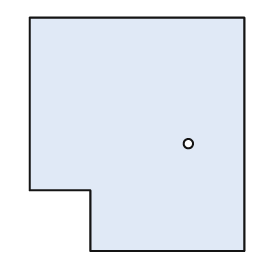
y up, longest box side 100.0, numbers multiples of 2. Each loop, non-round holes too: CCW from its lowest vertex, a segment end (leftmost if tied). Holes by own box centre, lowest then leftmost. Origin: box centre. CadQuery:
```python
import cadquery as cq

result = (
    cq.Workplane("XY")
    .moveTo(-20.0, -50.0)
    .lineTo(46.0, -50.0)
    .lineTo(46.0, 50.0)
    .lineTo(-46.0, 50.0)
    .lineTo(-46.0, -24.0)
    .lineTo(-20.0, -24.0)
    .close()
    .moveTo(22.0, -4.0)
    .circle(2.0)
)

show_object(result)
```